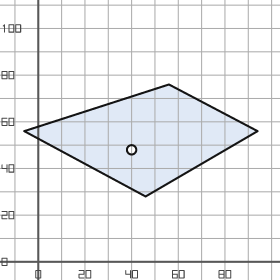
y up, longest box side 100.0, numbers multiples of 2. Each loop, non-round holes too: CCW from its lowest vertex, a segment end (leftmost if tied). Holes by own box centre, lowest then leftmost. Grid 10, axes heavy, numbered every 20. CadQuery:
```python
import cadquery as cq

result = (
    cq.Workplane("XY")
    .moveTo(46.0, 28.0)
    .lineTo(94.0, 56.0)
    .lineTo(56.0, 76.0)
    .lineTo(-6.0, 56.0)
    .close()
    .moveTo(40.0, 48.0)
    .circle(2.0)
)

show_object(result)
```